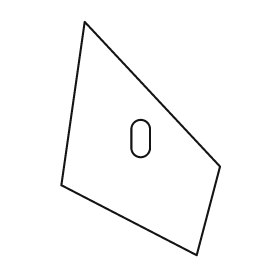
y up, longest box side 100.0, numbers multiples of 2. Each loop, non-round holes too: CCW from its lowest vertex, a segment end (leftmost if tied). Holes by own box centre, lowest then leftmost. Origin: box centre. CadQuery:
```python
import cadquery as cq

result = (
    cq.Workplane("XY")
    .moveTo(24.0, -50.0)
    .lineTo(34.0, -12.0)
    .lineTo(-24.0, 50.0)
    .lineTo(-34.0, -20.0)
    .close()
    .moveTo(-4.0, -4.0)
    .threePointArc((0.0, -8.0), (4.0, -4.0))
    .lineTo(4.0, 4.0)
    .threePointArc((0.0, 8.0), (-4.0, 4.0))
    .close()
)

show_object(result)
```